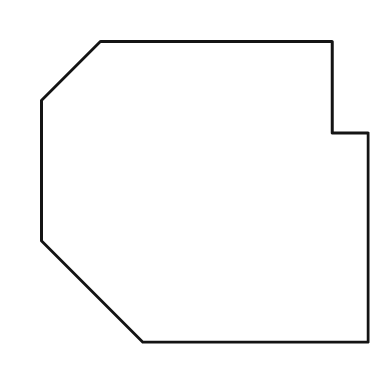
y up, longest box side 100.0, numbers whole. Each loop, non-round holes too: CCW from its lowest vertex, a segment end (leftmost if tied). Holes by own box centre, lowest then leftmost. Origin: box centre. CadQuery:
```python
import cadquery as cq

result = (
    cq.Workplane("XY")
    .moveTo(-19.0, -46.0)
    .lineTo(50.0, -46.0)
    .lineTo(50.0, 18.0)
    .lineTo(39.0, 18.0)
    .lineTo(39.0, 46.0)
    .lineTo(-32.0, 46.0)
    .lineTo(-50.0, 28.0)
    .lineTo(-50.0, -15.0)
    .close()
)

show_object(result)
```